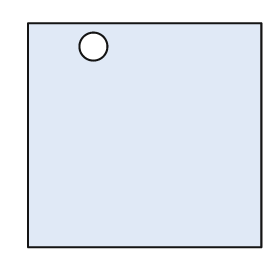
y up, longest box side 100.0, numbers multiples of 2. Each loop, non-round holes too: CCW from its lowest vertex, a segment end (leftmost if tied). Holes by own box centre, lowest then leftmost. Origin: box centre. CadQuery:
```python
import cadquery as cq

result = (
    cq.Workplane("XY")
    .moveTo(-50.0, -48.0)
    .lineTo(50.0, -48.0)
    .lineTo(50.0, 48.0)
    .lineTo(-50.0, 48.0)
    .close()
    .moveTo(-22.0, 38.0)
    .circle(6.0)
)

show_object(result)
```